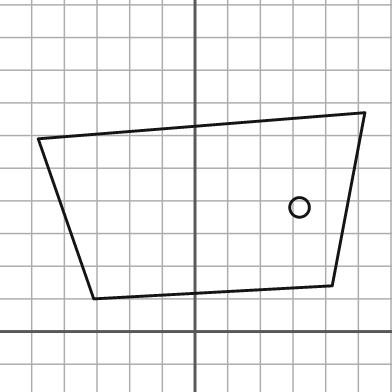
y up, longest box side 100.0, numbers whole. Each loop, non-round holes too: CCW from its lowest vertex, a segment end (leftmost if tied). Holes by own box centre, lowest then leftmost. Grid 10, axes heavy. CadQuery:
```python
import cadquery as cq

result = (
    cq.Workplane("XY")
    .moveTo(-31.0, 10.0)
    .lineTo(42.0, 14.0)
    .lineTo(52.0, 67.0)
    .lineTo(-48.0, 59.0)
    .close()
    .moveTo(32.0, 38.0)
    .circle(3.0)
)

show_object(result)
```